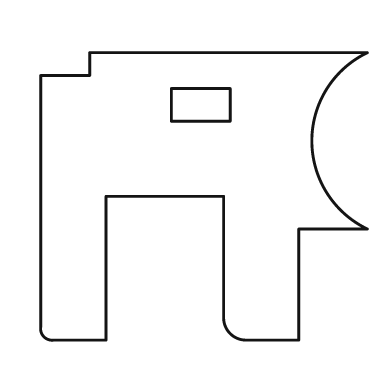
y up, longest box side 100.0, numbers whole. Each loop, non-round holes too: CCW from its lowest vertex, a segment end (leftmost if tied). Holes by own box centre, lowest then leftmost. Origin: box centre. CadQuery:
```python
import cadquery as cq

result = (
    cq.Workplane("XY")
    .moveTo(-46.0, -44.0)
    .lineTo(-30.0, -44.0)
    .lineTo(-30.0, 0.0)
    .lineTo(6.0, 0.0)
    .lineTo(6.0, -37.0)
    .threePointArc((8.0, -42.0), (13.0, -44.0))
    .lineTo(29.0, -44.0)
    .lineTo(29.0, -10.0)
    .lineTo(50.0, -10.0)
    .threePointArc((33.0, 17.0), (50.0, 44.0))
    .lineTo(-35.0, 44.0)
    .lineTo(-35.0, 37.0)
    .lineTo(-50.0, 37.0)
    .lineTo(-50.0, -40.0)
    .threePointArc((-49.0, -43.0), (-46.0, -44.0))
    .close()
    .moveTo(-10.0, 23.0)
    .lineTo(8.0, 23.0)
    .lineTo(8.0, 33.0)
    .lineTo(-10.0, 33.0)
    .close()
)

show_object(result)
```